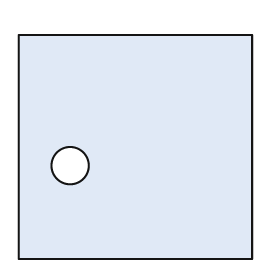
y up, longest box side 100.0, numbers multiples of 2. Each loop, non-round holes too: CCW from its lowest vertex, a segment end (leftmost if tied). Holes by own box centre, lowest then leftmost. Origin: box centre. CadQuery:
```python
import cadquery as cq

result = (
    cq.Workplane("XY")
    .moveTo(-50.0, -48.0)
    .lineTo(50.0, -48.0)
    .lineTo(50.0, 48.0)
    .lineTo(-50.0, 48.0)
    .close()
    .moveTo(-28.0, -8.0)
    .circle(8.0)
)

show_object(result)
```